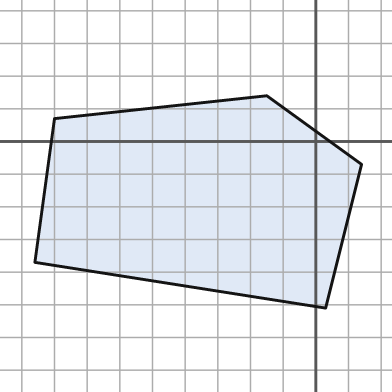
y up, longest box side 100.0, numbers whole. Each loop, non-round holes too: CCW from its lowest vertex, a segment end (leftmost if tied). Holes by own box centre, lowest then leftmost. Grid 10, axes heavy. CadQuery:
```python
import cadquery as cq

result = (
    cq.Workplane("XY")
    .moveTo(3.0, -51.0)
    .lineTo(14.0, -7.0)
    .lineTo(-15.0, 14.0)
    .lineTo(-80.0, 7.0)
    .lineTo(-86.0, -37.0)
    .close()
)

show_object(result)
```